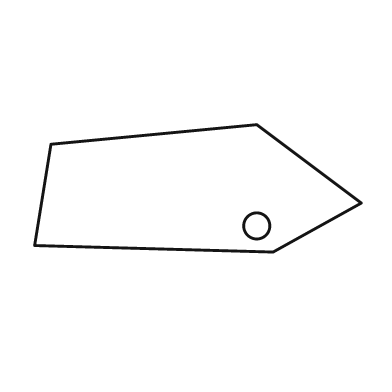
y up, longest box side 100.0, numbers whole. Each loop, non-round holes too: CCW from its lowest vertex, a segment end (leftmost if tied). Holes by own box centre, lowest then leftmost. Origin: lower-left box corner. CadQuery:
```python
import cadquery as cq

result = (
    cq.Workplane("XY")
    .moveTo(73.0, 0.0)
    .lineTo(100.0, 15.0)
    .lineTo(68.0, 39.0)
    .lineTo(5.0, 33.0)
    .lineTo(0.0, 2.0)
    .close()
    .moveTo(68.0, 8.0)
    .circle(4.0)
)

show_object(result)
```